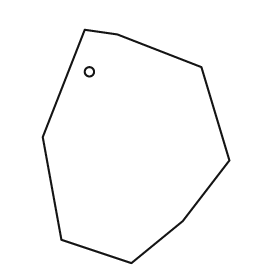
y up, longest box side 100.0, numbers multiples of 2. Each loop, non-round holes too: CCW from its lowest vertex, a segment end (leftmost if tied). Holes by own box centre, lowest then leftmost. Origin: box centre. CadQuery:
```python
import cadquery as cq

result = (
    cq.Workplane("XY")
    .moveTo(-2.0, -50.0)
    .lineTo(20.0, -32.0)
    .lineTo(40.0, -6.0)
    .lineTo(28.0, 34.0)
    .lineTo(-8.0, 48.0)
    .lineTo(-22.0, 50.0)
    .lineTo(-40.0, 4.0)
    .lineTo(-32.0, -40.0)
    .close()
    .moveTo(-20.0, 32.0)
    .circle(2.0)
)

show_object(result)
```